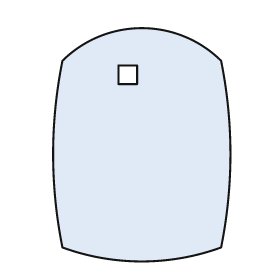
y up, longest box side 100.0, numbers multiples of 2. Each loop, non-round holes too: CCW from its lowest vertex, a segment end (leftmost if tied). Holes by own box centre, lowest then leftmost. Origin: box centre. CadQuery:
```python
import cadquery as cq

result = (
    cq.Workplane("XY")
    .moveTo(-34.0, -44.0)
    .threePointArc((0.0, -50.0), (34.0, -44.0))
    .threePointArc((38.0, -4.0), (34.0, 36.0))
    .threePointArc((0.0, 50.0), (-34.0, 36.0))
    .threePointArc((-38.0, -4.0), (-34.0, -44.0))
    .close()
    .moveTo(-10.0, 26.0)
    .lineTo(-2.0, 26.0)
    .lineTo(-2.0, 34.0)
    .lineTo(-10.0, 34.0)
    .close()
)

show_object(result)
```